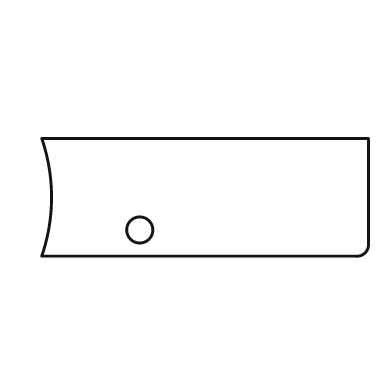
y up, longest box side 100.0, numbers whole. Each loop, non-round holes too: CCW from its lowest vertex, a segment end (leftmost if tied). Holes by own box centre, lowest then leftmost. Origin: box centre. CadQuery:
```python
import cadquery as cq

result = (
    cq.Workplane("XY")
    .moveTo(-50.0, -18.0)
    .lineTo(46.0, -18.0)
    .threePointArc((49.0, -17.0), (50.0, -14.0))
    .lineTo(50.0, 18.0)
    .lineTo(-50.0, 18.0)
    .threePointArc((-47.0, 0.0), (-50.0, -18.0))
    .close()
    .moveTo(-20.0, -10.0)
    .circle(4.0)
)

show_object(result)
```